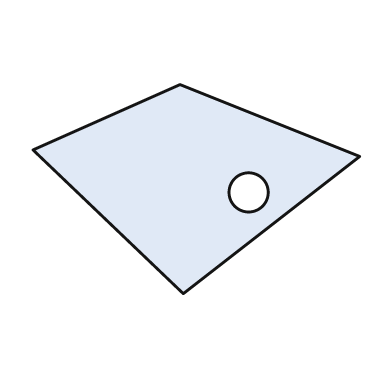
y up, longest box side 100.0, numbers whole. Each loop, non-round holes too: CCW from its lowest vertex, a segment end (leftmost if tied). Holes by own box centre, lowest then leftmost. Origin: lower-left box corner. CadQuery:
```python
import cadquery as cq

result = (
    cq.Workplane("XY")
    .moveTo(46.0, 0.0)
    .lineTo(100.0, 42.0)
    .lineTo(45.0, 64.0)
    .lineTo(0.0, 44.0)
    .close()
    .moveTo(66.0, 31.0)
    .circle(6.0)
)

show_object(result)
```